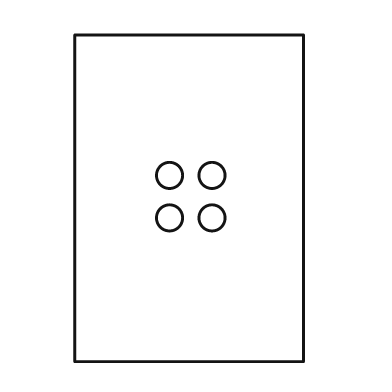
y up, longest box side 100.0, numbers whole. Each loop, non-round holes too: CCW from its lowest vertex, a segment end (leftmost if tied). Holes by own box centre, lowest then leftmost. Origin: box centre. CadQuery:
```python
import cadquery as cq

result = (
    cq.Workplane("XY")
    .moveTo(-35.0, -50.0)
    .lineTo(35.0, -50.0)
    .lineTo(35.0, 50.0)
    .lineTo(-35.0, 50.0)
    .close()
    .moveTo(-6.0, -6.0)
    .circle(4.0)
    .moveTo(7.0, -6.0)
    .circle(4.0)
    .moveTo(-6.0, 7.0)
    .circle(4.0)
    .moveTo(7.0, 7.0)
    .circle(4.0)
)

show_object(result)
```